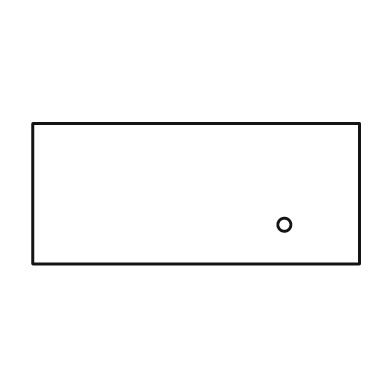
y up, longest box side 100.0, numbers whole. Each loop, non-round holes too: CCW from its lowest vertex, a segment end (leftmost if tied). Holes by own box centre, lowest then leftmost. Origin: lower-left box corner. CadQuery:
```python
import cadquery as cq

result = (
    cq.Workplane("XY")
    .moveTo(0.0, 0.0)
    .lineTo(100.0, 0.0)
    .lineTo(100.0, 43.0)
    .lineTo(0.0, 43.0)
    .close()
    .moveTo(77.0, 12.0)
    .circle(2.0)
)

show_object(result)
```